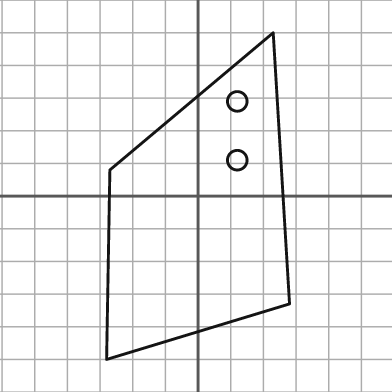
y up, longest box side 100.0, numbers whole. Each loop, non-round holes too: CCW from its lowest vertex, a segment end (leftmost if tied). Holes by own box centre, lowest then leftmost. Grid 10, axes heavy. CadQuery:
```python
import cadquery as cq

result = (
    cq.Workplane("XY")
    .moveTo(-28.0, -50.0)
    .lineTo(28.0, -33.0)
    .lineTo(23.0, 50.0)
    .lineTo(-27.0, 8.0)
    .close()
    .moveTo(12.0, 11.0)
    .circle(3.0)
    .moveTo(12.0, 29.0)
    .circle(3.0)
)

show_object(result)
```